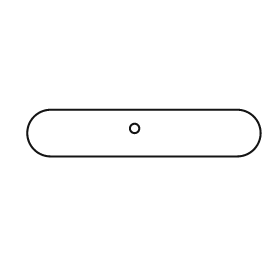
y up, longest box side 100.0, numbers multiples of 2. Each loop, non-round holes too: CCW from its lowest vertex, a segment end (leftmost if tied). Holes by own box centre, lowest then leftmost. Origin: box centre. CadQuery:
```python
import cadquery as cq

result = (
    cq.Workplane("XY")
    .moveTo(-40.0, -10.0)
    .lineTo(40.0, -10.0)
    .threePointArc((50.0, 0.0), (40.0, 10.0))
    .lineTo(-40.0, 10.0)
    .threePointArc((-50.0, 0.0), (-40.0, -10.0))
    .close()
    .moveTo(-4.0, 2.0)
    .circle(2.0)
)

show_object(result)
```